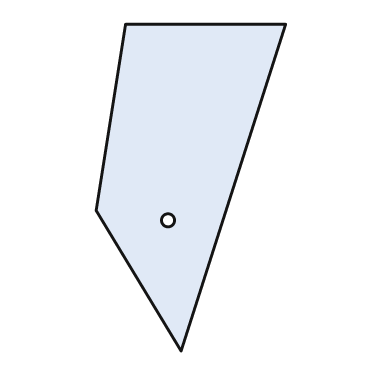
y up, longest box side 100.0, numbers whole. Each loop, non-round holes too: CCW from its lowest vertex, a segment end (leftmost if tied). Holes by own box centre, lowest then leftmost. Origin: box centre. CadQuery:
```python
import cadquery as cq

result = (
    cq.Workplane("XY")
    .moveTo(-3.0, -50.0)
    .lineTo(29.0, 50.0)
    .lineTo(-20.0, 50.0)
    .lineTo(-29.0, -7.0)
    .close()
    .moveTo(-7.0, -10.0)
    .circle(2.0)
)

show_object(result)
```